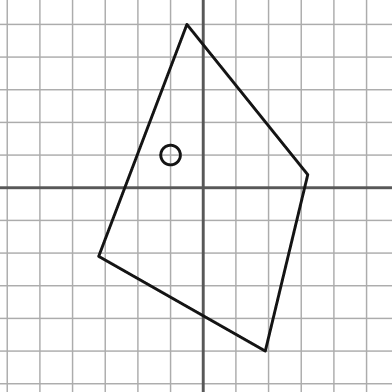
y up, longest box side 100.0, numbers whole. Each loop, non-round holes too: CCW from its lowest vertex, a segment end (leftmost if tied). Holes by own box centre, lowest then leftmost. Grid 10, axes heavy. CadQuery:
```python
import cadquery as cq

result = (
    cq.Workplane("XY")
    .moveTo(19.0, -50.0)
    .lineTo(32.0, 4.0)
    .lineTo(-5.0, 50.0)
    .lineTo(-32.0, -21.0)
    .close()
    .moveTo(-10.0, 10.0)
    .circle(3.0)
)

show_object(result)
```